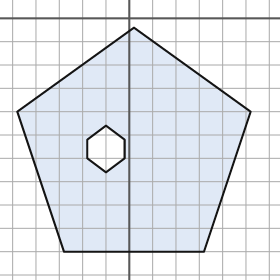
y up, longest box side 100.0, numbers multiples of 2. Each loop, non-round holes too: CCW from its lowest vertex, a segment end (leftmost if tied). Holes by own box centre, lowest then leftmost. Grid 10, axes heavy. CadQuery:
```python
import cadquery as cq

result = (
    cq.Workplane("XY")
    .moveTo(-28.0, -100.0)
    .lineTo(32.0, -100.0)
    .lineTo(52.0, -40.0)
    .lineTo(2.0, -4.0)
    .lineTo(-48.0, -40.0)
    .close()
    .moveTo(-10.0, -66.0)
    .lineTo(-2.0, -60.0)
    .lineTo(-2.0, -52.0)
    .lineTo(-10.0, -46.0)
    .lineTo(-18.0, -52.0)
    .lineTo(-18.0, -60.0)
    .close()
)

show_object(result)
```